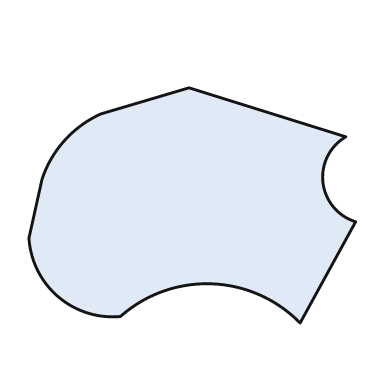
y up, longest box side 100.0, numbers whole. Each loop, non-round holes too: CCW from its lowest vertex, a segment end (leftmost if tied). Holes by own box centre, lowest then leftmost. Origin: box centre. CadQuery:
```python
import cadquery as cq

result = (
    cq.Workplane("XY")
    .moveTo(33.0, -36.0)
    .lineTo(50.0, -5.0)
    .threePointArc((40.0, 7.0), (47.0, 21.0))
    .lineTo(-1.0, 36.0)
    .lineTo(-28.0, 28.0)
    .threePointArc((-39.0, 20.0), (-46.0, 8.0))
    .lineTo(-50.0, -10.0)
    .threePointArc((-41.0, -28.0), (-22.0, -34.0))
    .threePointArc((6.0, -24.0), (33.0, -36.0))
    .close()
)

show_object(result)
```